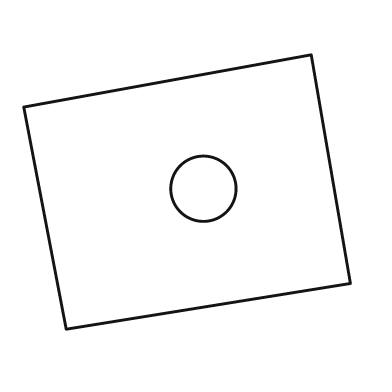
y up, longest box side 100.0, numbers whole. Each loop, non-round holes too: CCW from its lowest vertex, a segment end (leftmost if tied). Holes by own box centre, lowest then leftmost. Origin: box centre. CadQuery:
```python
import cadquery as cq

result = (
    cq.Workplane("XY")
    .moveTo(-37.0, -42.0)
    .lineTo(50.0, -28.0)
    .lineTo(38.0, 42.0)
    .lineTo(-50.0, 26.0)
    .close()
    .moveTo(5.0, 1.0)
    .circle(10.0)
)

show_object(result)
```